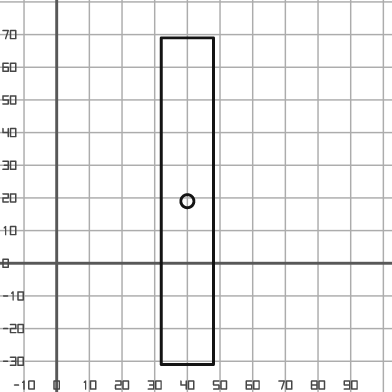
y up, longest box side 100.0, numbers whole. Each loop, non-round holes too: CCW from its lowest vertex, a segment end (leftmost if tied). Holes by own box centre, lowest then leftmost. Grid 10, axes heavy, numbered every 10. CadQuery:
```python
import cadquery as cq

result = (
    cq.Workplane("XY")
    .moveTo(32.0, -31.0)
    .lineTo(48.0, -31.0)
    .lineTo(48.0, 69.0)
    .lineTo(32.0, 69.0)
    .close()
    .moveTo(40.0, 19.0)
    .circle(2.0)
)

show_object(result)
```